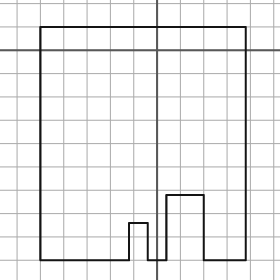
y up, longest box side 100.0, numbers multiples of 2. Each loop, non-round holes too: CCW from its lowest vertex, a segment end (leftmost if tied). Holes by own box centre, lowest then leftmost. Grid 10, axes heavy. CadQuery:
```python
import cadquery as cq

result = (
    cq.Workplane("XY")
    .moveTo(-50.0, -90.0)
    .lineTo(-12.0, -90.0)
    .lineTo(-12.0, -74.0)
    .lineTo(-4.0, -74.0)
    .lineTo(-4.0, -90.0)
    .lineTo(4.0, -90.0)
    .lineTo(4.0, -62.0)
    .lineTo(20.0, -62.0)
    .lineTo(20.0, -90.0)
    .lineTo(38.0, -90.0)
    .lineTo(38.0, 10.0)
    .lineTo(-50.0, 10.0)
    .close()
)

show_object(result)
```